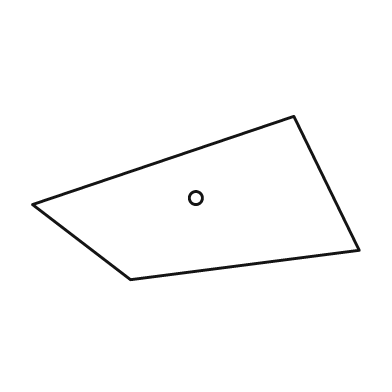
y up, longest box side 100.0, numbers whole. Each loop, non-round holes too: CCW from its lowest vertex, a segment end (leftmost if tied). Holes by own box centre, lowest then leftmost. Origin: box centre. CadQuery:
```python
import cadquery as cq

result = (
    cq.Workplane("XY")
    .moveTo(-20.0, -25.0)
    .lineTo(50.0, -16.0)
    .lineTo(30.0, 25.0)
    .lineTo(-50.0, -2.0)
    .close()
    .moveTo(0.0, 0.0)
    .circle(2.0)
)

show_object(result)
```